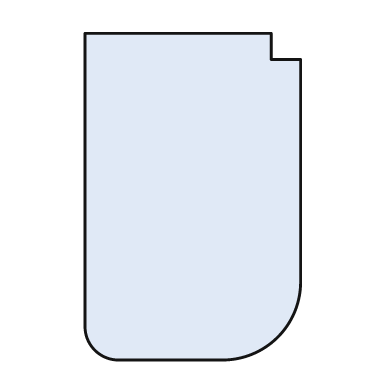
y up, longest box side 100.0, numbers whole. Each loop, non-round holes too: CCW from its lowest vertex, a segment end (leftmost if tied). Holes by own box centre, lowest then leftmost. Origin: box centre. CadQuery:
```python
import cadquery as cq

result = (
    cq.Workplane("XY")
    .moveTo(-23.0, -50.0)
    .lineTo(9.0, -50.0)
    .threePointArc((26.0, -43.0), (33.0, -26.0))
    .lineTo(33.0, 42.0)
    .lineTo(24.0, 42.0)
    .lineTo(24.0, 50.0)
    .lineTo(-33.0, 50.0)
    .lineTo(-33.0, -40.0)
    .threePointArc((-30.0, -47.0), (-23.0, -50.0))
    .close()
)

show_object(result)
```